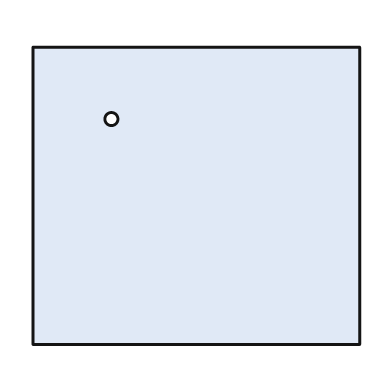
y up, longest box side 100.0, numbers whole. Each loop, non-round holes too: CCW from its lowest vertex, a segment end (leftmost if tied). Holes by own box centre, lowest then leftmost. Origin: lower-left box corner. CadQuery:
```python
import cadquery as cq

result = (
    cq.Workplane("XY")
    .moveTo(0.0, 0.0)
    .lineTo(100.0, 0.0)
    .lineTo(100.0, 91.0)
    .lineTo(0.0, 91.0)
    .close()
    .moveTo(24.0, 69.0)
    .circle(2.0)
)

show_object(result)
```